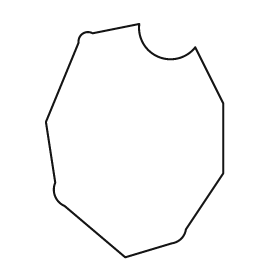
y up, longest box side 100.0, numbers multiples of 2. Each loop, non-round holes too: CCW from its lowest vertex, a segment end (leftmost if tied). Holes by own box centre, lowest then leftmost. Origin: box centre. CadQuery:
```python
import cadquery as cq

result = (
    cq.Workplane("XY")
    .moveTo(-4.0, -50.0)
    .lineTo(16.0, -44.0)
    .threePointArc((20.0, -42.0), (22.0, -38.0))
    .lineTo(38.0, -14.0)
    .lineTo(38.0, 16.0)
    .lineTo(26.0, 40.0)
    .threePointArc((10.0, 36.0), (2.0, 50.0))
    .lineTo(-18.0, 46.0)
    .threePointArc((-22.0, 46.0), (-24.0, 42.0))
    .lineTo(-38.0, 8.0)
    .lineTo(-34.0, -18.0)
    .threePointArc((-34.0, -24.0), (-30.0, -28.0))
    .close()
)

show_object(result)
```